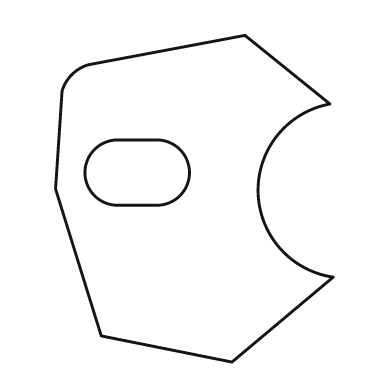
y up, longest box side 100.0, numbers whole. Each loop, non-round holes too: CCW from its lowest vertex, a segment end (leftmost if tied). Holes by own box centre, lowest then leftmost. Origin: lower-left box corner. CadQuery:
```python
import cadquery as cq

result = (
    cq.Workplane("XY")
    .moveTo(54.0, 0.0)
    .lineTo(85.0, 26.0)
    .threePointArc((62.0, 52.0), (84.0, 79.0))
    .lineTo(58.0, 100.0)
    .lineTo(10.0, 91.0)
    .threePointArc((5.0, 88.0), (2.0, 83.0))
    .lineTo(0.0, 53.0)
    .lineTo(14.0, 8.0)
    .close()
    .moveTo(19.0, 48.0)
    .lineTo(31.0, 48.0)
    .threePointArc((41.0, 58.0), (31.0, 68.0))
    .lineTo(19.0, 68.0)
    .threePointArc((9.0, 58.0), (19.0, 48.0))
    .close()
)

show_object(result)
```